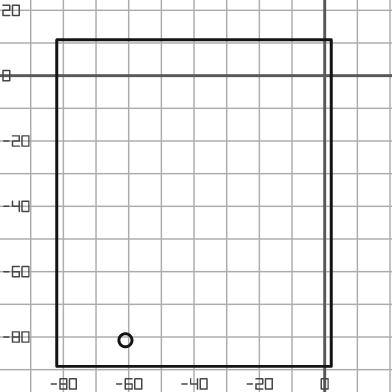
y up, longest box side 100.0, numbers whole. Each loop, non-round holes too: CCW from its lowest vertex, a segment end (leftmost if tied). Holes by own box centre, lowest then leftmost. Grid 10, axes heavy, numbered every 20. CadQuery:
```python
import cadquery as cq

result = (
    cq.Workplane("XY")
    .moveTo(-82.0, -89.0)
    .lineTo(2.0, -89.0)
    .lineTo(2.0, 11.0)
    .lineTo(-82.0, 11.0)
    .close()
    .moveTo(-61.0, -81.0)
    .circle(2.0)
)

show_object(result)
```